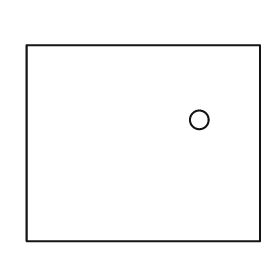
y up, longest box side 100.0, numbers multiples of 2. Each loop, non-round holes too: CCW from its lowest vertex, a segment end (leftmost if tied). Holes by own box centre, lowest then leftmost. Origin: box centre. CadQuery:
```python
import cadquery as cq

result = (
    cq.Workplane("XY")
    .moveTo(-50.0, -42.0)
    .lineTo(50.0, -42.0)
    .lineTo(50.0, 42.0)
    .lineTo(-50.0, 42.0)
    .close()
    .moveTo(24.0, 10.0)
    .circle(4.0)
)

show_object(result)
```